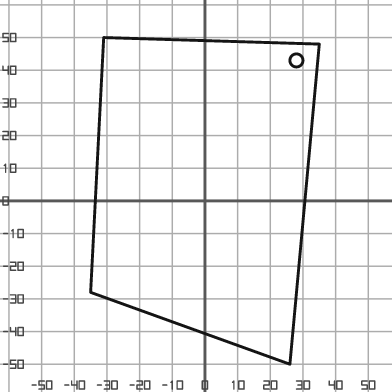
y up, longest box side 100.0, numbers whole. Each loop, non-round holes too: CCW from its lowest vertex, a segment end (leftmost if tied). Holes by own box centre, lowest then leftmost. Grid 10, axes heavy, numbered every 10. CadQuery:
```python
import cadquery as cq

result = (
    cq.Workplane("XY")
    .moveTo(26.0, -50.0)
    .lineTo(35.0, 48.0)
    .lineTo(-31.0, 50.0)
    .lineTo(-35.0, -28.0)
    .close()
    .moveTo(28.0, 43.0)
    .circle(2.0)
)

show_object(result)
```